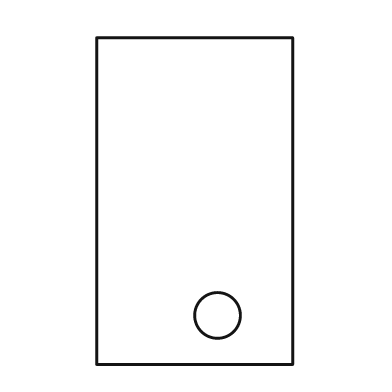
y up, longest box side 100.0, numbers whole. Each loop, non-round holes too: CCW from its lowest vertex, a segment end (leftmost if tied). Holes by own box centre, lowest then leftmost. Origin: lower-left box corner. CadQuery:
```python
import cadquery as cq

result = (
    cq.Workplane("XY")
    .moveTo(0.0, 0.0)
    .lineTo(60.0, 0.0)
    .lineTo(60.0, 100.0)
    .lineTo(0.0, 100.0)
    .close()
    .moveTo(37.0, 15.0)
    .circle(7.0)
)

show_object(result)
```